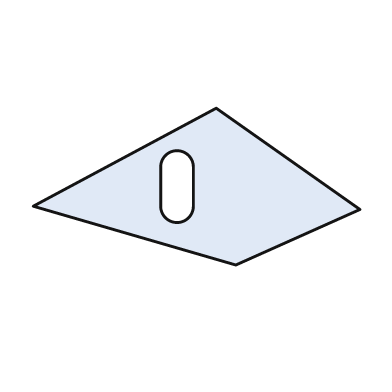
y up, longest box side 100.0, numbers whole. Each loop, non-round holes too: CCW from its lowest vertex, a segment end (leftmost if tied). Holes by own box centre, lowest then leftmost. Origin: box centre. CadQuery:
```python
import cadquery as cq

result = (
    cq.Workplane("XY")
    .moveTo(12.0, -24.0)
    .lineTo(50.0, -7.0)
    .lineTo(6.0, 24.0)
    .lineTo(-50.0, -6.0)
    .close()
    .moveTo(-11.0, -6.0)
    .threePointArc((-6.0, -11.0), (-1.0, -6.0))
    .lineTo(-1.0, 6.0)
    .threePointArc((-6.0, 11.0), (-11.0, 6.0))
    .close()
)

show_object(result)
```